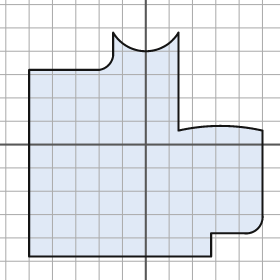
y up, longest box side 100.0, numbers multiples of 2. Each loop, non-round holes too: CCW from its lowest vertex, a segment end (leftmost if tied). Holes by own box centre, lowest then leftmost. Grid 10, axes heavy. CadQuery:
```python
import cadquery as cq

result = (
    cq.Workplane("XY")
    .moveTo(-50.0, -48.0)
    .lineTo(28.0, -48.0)
    .lineTo(28.0, -38.0)
    .lineTo(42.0, -38.0)
    .threePointArc((48.0, -36.0), (50.0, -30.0))
    .lineTo(50.0, 6.0)
    .threePointArc((32.0, 8.0), (14.0, 6.0))
    .lineTo(14.0, 48.0)
    .threePointArc((0.0, 40.0), (-14.0, 48.0))
    .lineTo(-14.0, 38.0)
    .threePointArc((-16.0, 34.0), (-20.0, 32.0))
    .lineTo(-50.0, 32.0)
    .close()
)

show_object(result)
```